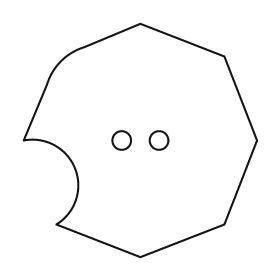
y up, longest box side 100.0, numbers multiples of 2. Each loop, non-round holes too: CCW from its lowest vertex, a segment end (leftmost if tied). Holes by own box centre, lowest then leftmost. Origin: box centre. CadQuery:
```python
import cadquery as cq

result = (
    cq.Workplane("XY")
    .moveTo(0.0, -50.0)
    .lineTo(36.0, -36.0)
    .lineTo(50.0, 0.0)
    .lineTo(36.0, 36.0)
    .lineTo(0.0, 50.0)
    .lineTo(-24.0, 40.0)
    .threePointArc((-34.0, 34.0), (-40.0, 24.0))
    .lineTo(-50.0, 0.0)
    .threePointArc((-28.0, -12.0), (-36.0, -36.0))
    .close()
    .moveTo(-8.0, 0.0)
    .circle(4.0)
    .moveTo(8.0, 0.0)
    .circle(4.0)
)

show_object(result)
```